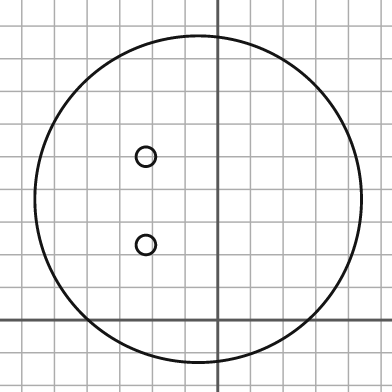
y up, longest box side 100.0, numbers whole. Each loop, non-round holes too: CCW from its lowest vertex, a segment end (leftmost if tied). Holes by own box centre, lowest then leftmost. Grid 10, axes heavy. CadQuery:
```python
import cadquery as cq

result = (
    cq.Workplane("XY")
    .moveTo(-6.0, 37.0)
    .circle(50.0)
    .moveTo(-22.0, 23.0)
    .circle(3.0)
    .moveTo(-22.0, 50.0)
    .circle(3.0)
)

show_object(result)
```